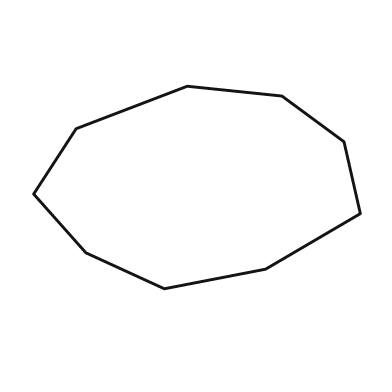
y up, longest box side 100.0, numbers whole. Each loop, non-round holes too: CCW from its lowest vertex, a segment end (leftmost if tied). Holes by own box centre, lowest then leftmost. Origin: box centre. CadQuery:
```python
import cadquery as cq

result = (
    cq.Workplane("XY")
    .moveTo(-10.0, -31.0)
    .lineTo(21.0, -25.0)
    .lineTo(50.0, -8.0)
    .lineTo(45.0, 14.0)
    .lineTo(26.0, 28.0)
    .lineTo(-3.0, 31.0)
    .lineTo(-37.0, 18.0)
    .lineTo(-50.0, -2.0)
    .lineTo(-34.0, -20.0)
    .close()
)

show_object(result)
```